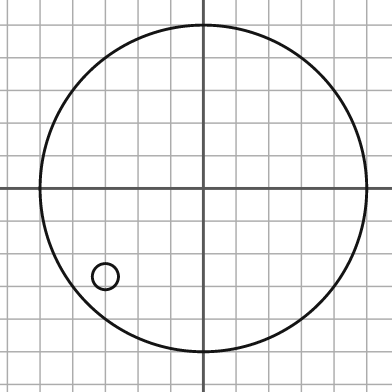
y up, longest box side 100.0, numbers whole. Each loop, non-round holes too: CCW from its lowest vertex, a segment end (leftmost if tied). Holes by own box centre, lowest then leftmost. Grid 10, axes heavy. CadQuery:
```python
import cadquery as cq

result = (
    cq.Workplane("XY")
    .moveTo(0.0, 0.0)
    .circle(50.0)
    .moveTo(-30.0, -27.0)
    .circle(4.0)
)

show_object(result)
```